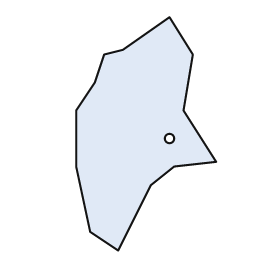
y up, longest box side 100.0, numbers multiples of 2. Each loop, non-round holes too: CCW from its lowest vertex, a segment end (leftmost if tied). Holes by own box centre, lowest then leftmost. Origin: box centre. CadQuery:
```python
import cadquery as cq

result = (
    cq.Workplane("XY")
    .moveTo(-12.0, -50.0)
    .lineTo(2.0, -22.0)
    .lineTo(12.0, -14.0)
    .lineTo(30.0, -12.0)
    .lineTo(16.0, 10.0)
    .lineTo(20.0, 34.0)
    .lineTo(10.0, 50.0)
    .lineTo(-10.0, 36.0)
    .lineTo(-18.0, 34.0)
    .lineTo(-22.0, 22.0)
    .lineTo(-30.0, 10.0)
    .lineTo(-30.0, -14.0)
    .lineTo(-24.0, -42.0)
    .close()
    .moveTo(10.0, -2.0)
    .circle(2.0)
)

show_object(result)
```